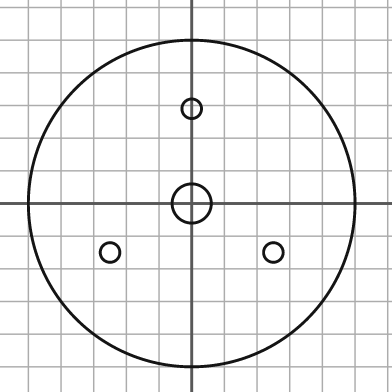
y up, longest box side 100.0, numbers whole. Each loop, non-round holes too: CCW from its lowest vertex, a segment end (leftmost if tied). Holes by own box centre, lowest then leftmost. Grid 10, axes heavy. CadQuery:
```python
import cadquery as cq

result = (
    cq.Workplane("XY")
    .moveTo(0.0, 0.0)
    .circle(50.0)
    .moveTo(-25.0, -15.0)
    .circle(3.0)
    .moveTo(25.0, -15.0)
    .circle(3.0)
    .moveTo(0.0, 0.0)
    .circle(6.0)
    .moveTo(0.0, 29.0)
    .circle(3.0)
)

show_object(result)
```